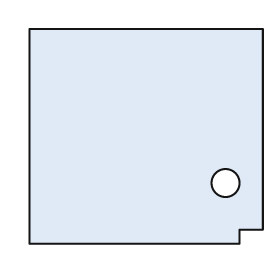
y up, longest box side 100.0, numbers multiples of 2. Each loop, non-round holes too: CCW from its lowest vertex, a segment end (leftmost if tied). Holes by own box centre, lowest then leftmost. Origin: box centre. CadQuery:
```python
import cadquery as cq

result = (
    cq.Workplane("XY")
    .moveTo(-50.0, -46.0)
    .lineTo(40.0, -46.0)
    .lineTo(40.0, -40.0)
    .lineTo(50.0, -40.0)
    .lineTo(50.0, 46.0)
    .lineTo(-50.0, 46.0)
    .close()
    .moveTo(34.0, -20.0)
    .circle(6.0)
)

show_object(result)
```